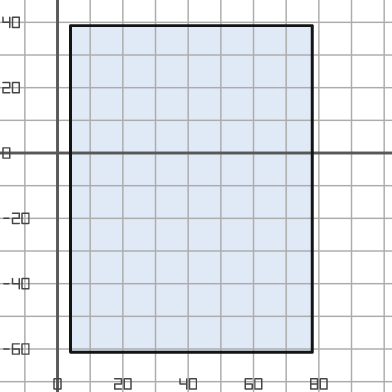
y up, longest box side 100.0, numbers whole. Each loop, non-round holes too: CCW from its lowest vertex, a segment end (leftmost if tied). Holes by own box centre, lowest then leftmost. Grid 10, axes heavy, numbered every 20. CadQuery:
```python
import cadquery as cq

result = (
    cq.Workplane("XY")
    .moveTo(4.0, -61.0)
    .lineTo(78.0, -61.0)
    .lineTo(78.0, 39.0)
    .lineTo(4.0, 39.0)
    .close()
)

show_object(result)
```